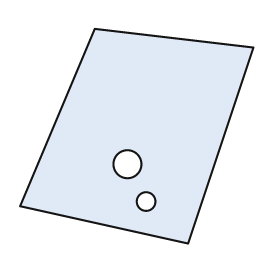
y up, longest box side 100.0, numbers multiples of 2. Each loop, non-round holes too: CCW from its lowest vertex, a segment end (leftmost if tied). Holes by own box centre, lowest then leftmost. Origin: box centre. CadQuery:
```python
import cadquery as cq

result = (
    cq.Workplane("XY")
    .moveTo(22.0, -46.0)
    .lineTo(50.0, 38.0)
    .lineTo(-18.0, 46.0)
    .lineTo(-50.0, -30.0)
    .close()
    .moveTo(4.0, -28.0)
    .circle(4.0)
    .moveTo(-4.0, -12.0)
    .circle(6.0)
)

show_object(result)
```